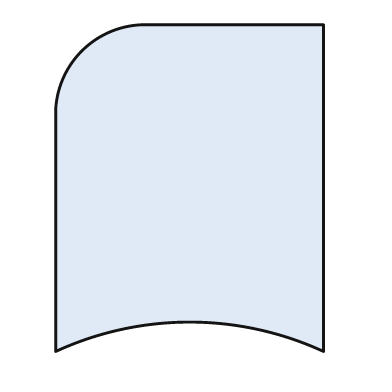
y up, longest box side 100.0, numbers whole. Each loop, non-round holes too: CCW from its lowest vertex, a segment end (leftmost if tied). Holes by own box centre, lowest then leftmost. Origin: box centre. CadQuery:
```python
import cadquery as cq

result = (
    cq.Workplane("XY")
    .moveTo(-41.0, -50.0)
    .threePointArc((0.0, -41.0), (41.0, -50.0))
    .lineTo(41.0, 50.0)
    .lineTo(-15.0, 50.0)
    .threePointArc((-33.0, 42.0), (-41.0, 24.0))
    .close()
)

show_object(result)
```